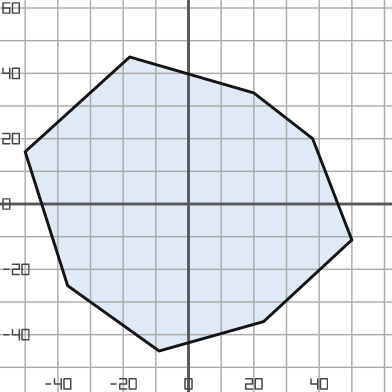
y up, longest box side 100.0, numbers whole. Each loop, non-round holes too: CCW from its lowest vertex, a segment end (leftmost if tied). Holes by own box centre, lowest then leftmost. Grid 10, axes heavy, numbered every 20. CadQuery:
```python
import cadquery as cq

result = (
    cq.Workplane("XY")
    .moveTo(-9.0, -45.0)
    .lineTo(23.0, -36.0)
    .lineTo(50.0, -11.0)
    .lineTo(38.0, 20.0)
    .lineTo(20.0, 34.0)
    .lineTo(-18.0, 45.0)
    .lineTo(-50.0, 16.0)
    .lineTo(-37.0, -25.0)
    .close()
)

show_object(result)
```